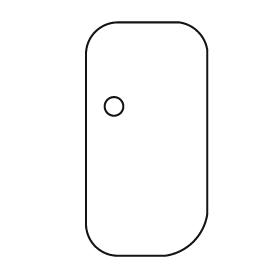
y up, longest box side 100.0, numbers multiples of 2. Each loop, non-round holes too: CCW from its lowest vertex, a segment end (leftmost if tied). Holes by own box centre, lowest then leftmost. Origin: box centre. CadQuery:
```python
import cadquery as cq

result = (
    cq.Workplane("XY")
    .moveTo(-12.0, -50.0)
    .lineTo(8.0, -50.0)
    .threePointArc((20.0, -44.0), (26.0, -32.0))
    .lineTo(26.0, 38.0)
    .threePointArc((22.0, 46.0), (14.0, 50.0))
    .lineTo(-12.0, 50.0)
    .threePointArc((-22.0, 46.0), (-26.0, 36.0))
    .lineTo(-26.0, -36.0)
    .threePointArc((-22.0, -46.0), (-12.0, -50.0))
    .close()
    .moveTo(-14.0, 14.0)
    .circle(4.0)
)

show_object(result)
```